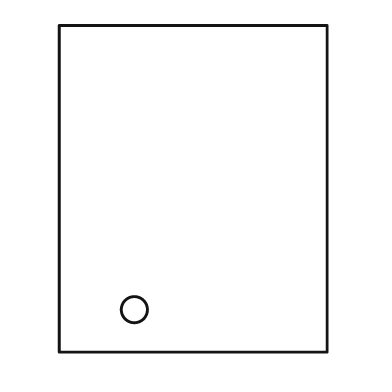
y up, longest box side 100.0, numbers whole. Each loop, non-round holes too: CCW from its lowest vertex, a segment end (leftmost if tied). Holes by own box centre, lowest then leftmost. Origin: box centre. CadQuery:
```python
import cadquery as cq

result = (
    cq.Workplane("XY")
    .moveTo(-41.0, -50.0)
    .lineTo(41.0, -50.0)
    .lineTo(41.0, 50.0)
    .lineTo(-41.0, 50.0)
    .close()
    .moveTo(-18.0, -37.0)
    .circle(4.0)
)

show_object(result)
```